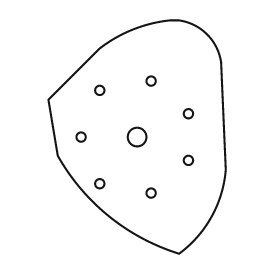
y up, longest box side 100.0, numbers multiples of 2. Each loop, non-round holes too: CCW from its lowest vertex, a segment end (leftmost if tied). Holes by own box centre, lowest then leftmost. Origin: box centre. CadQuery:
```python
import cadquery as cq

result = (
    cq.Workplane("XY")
    .moveTo(18.0, -50.0)
    .threePointArc((32.0, -34.0), (38.0, -14.0))
    .lineTo(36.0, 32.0)
    .threePointArc((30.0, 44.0), (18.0, 50.0))
    .lineTo(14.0, 50.0)
    .threePointArc((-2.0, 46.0), (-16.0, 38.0))
    .lineTo(-38.0, 16.0)
    .lineTo(-34.0, -8.0)
    .threePointArc((-12.0, -34.0), (18.0, -50.0))
    .close()
    .moveTo(6.0, -24.0)
    .circle(2.0)
    .moveTo(-16.0, -20.0)
    .circle(2.0)
    .moveTo(22.0, -10.0)
    .circle(2.0)
    .moveTo(-24.0, 0.0)
    .circle(2.0)
    .moveTo(0.0, 0.0)
    .circle(4.0)
    .moveTo(22.0, 10.0)
    .circle(2.0)
    .moveTo(-16.0, 20.0)
    .circle(2.0)
    .moveTo(6.0, 24.0)
    .circle(2.0)
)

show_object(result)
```